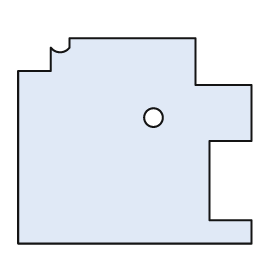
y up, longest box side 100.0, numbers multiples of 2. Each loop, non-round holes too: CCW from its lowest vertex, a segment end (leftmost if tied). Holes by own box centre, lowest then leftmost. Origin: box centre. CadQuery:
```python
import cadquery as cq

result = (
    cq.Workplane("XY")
    .moveTo(-50.0, -44.0)
    .lineTo(50.0, -44.0)
    .lineTo(50.0, -34.0)
    .lineTo(32.0, -34.0)
    .lineTo(32.0, 0.0)
    .lineTo(50.0, 0.0)
    .lineTo(50.0, 24.0)
    .lineTo(26.0, 24.0)
    .lineTo(26.0, 44.0)
    .lineTo(-28.0, 44.0)
    .lineTo(-28.0, 40.0)
    .threePointArc((-32.0, 38.0), (-36.0, 40.0))
    .lineTo(-36.0, 30.0)
    .lineTo(-50.0, 30.0)
    .close()
    .moveTo(8.0, 10.0)
    .circle(4.0)
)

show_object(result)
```